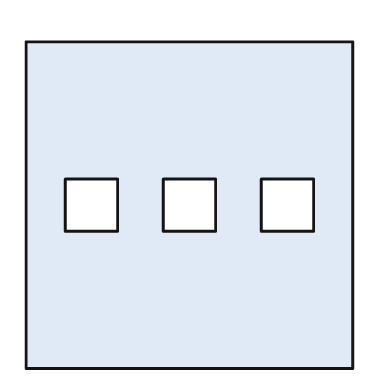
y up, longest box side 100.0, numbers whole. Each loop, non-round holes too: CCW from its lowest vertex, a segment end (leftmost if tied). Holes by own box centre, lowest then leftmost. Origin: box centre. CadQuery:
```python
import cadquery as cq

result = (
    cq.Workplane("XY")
    .moveTo(-50.0, -50.0)
    .lineTo(50.0, -50.0)
    .lineTo(50.0, 50.0)
    .lineTo(-50.0, 50.0)
    .close()
    .moveTo(-38.0, -8.0)
    .lineTo(-22.0, -8.0)
    .lineTo(-22.0, 8.0)
    .lineTo(-38.0, 8.0)
    .close()
    .moveTo(-8.0, -8.0)
    .lineTo(8.0, -8.0)
    .lineTo(8.0, 8.0)
    .lineTo(-8.0, 8.0)
    .close()
    .moveTo(22.0, -8.0)
    .lineTo(38.0, -8.0)
    .lineTo(38.0, 8.0)
    .lineTo(22.0, 8.0)
    .close()
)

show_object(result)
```